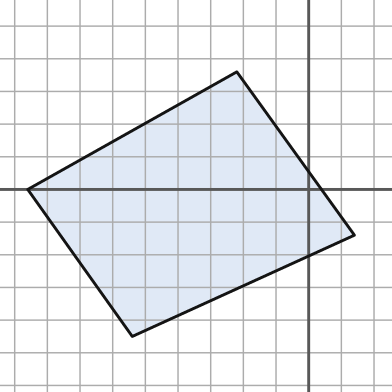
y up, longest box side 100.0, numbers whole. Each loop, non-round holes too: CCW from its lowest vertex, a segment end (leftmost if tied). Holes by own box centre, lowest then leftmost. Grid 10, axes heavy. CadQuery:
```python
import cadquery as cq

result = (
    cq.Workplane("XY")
    .moveTo(-54.0, -45.0)
    .lineTo(14.0, -14.0)
    .lineTo(-22.0, 36.0)
    .lineTo(-86.0, 0.0)
    .close()
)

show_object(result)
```